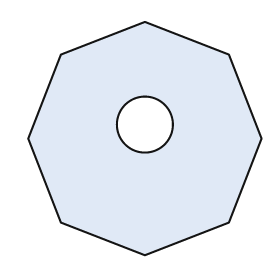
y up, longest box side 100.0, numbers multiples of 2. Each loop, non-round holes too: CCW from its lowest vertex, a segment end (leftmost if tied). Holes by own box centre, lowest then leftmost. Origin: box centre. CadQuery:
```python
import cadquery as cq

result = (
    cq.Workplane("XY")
    .moveTo(0.0, -50.0)
    .lineTo(36.0, -36.0)
    .lineTo(50.0, 0.0)
    .lineTo(36.0, 36.0)
    .lineTo(0.0, 50.0)
    .lineTo(-36.0, 36.0)
    .lineTo(-50.0, 0.0)
    .lineTo(-36.0, -36.0)
    .close()
    .moveTo(0.0, 6.0)
    .circle(12.0)
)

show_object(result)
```